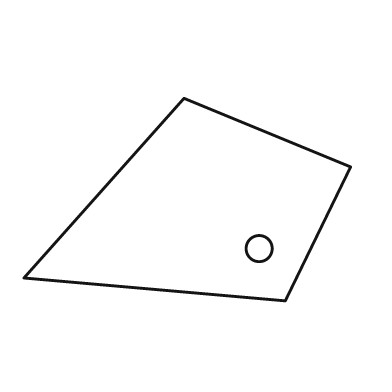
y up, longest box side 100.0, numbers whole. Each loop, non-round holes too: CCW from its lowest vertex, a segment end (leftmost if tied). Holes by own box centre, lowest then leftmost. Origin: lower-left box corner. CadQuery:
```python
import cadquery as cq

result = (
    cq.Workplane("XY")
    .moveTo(80.0, 0.0)
    .lineTo(100.0, 41.0)
    .lineTo(49.0, 62.0)
    .lineTo(0.0, 7.0)
    .close()
    .moveTo(72.0, 16.0)
    .circle(4.0)
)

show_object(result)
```